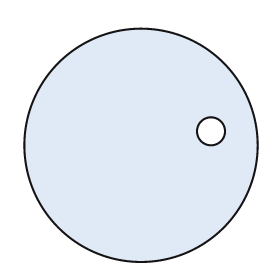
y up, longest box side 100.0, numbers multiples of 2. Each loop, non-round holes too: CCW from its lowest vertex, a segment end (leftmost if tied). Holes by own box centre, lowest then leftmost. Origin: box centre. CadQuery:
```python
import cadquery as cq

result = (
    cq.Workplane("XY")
    .moveTo(0.0, 0.0)
    .circle(50.0)
    .moveTo(30.0, 6.0)
    .circle(6.0)
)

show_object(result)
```